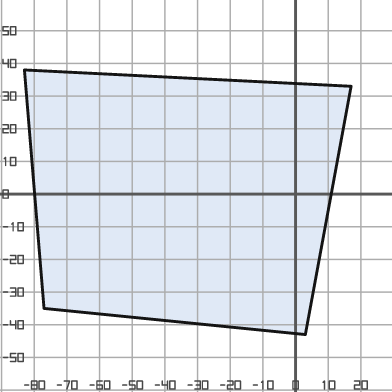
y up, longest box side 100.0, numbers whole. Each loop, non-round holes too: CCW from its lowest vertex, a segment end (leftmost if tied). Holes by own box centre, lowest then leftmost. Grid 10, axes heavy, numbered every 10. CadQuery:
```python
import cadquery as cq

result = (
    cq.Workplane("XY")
    .moveTo(3.0, -43.0)
    .lineTo(17.0, 33.0)
    .lineTo(-83.0, 38.0)
    .lineTo(-77.0, -35.0)
    .close()
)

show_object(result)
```